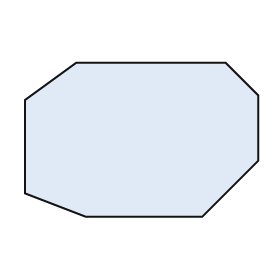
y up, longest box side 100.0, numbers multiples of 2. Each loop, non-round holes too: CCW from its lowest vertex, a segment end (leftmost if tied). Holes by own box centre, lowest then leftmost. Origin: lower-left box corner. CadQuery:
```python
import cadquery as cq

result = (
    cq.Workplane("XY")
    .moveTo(26.0, 0.0)
    .lineTo(76.0, 0.0)
    .lineTo(100.0, 24.0)
    .lineTo(100.0, 52.0)
    .lineTo(86.0, 66.0)
    .lineTo(22.0, 66.0)
    .lineTo(0.0, 50.0)
    .lineTo(0.0, 10.0)
    .close()
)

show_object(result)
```